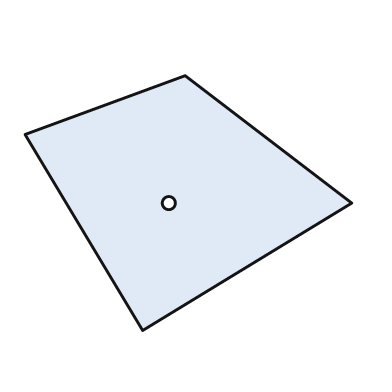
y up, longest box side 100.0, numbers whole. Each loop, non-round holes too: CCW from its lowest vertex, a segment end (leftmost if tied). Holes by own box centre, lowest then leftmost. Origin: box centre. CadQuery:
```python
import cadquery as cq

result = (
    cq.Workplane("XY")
    .moveTo(-14.0, -39.0)
    .lineTo(50.0, 0.0)
    .lineTo(-1.0, 39.0)
    .lineTo(-50.0, 21.0)
    .close()
    .moveTo(-6.0, 0.0)
    .circle(2.0)
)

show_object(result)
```